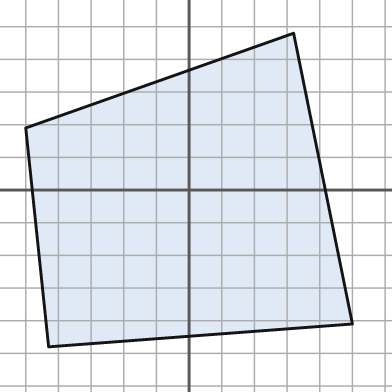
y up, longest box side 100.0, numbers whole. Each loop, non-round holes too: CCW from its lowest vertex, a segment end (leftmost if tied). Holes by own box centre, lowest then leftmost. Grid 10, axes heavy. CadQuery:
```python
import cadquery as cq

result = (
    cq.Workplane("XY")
    .moveTo(-43.0, -48.0)
    .lineTo(50.0, -41.0)
    .lineTo(32.0, 48.0)
    .lineTo(-50.0, 19.0)
    .close()
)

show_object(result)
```